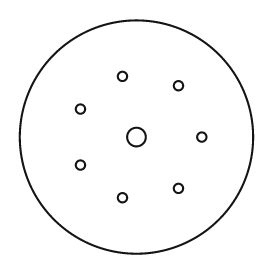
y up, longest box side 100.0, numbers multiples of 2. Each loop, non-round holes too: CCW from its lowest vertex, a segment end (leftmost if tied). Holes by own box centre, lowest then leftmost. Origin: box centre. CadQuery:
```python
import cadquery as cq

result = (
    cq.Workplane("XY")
    .moveTo(0.0, 0.0)
    .circle(50.0)
    .moveTo(-6.0, -26.0)
    .circle(2.0)
    .moveTo(18.0, -22.0)
    .circle(2.0)
    .moveTo(-24.0, -12.0)
    .circle(2.0)
    .moveTo(0.0, 0.0)
    .circle(4.0)
    .moveTo(28.0, 0.0)
    .circle(2.0)
    .moveTo(-24.0, 12.0)
    .circle(2.0)
    .moveTo(18.0, 22.0)
    .circle(2.0)
    .moveTo(-6.0, 26.0)
    .circle(2.0)
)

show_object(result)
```